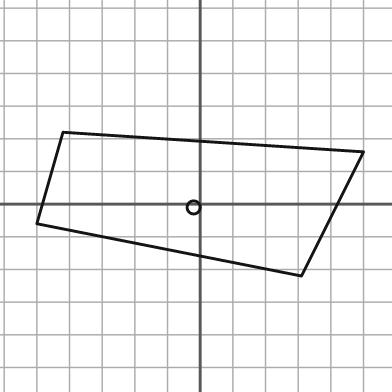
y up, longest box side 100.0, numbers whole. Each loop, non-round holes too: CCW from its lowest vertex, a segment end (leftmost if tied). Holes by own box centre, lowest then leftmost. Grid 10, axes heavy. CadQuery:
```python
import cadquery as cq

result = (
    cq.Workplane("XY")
    .moveTo(31.0, -22.0)
    .lineTo(50.0, 16.0)
    .lineTo(-42.0, 22.0)
    .lineTo(-50.0, -6.0)
    .close()
    .moveTo(-2.0, -1.0)
    .circle(2.0)
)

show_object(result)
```